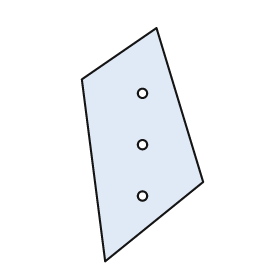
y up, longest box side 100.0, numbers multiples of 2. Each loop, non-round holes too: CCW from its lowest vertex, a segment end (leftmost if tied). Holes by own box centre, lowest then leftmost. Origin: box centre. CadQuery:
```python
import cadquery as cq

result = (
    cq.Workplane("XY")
    .moveTo(-16.0, -50.0)
    .lineTo(26.0, -16.0)
    .lineTo(6.0, 50.0)
    .lineTo(-26.0, 28.0)
    .close()
    .moveTo(0.0, -22.0)
    .circle(2.0)
    .moveTo(0.0, 0.0)
    .circle(2.0)
    .moveTo(0.0, 22.0)
    .circle(2.0)
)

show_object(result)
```